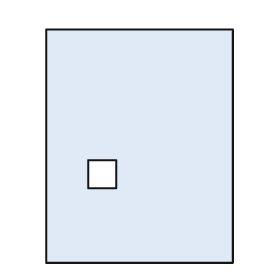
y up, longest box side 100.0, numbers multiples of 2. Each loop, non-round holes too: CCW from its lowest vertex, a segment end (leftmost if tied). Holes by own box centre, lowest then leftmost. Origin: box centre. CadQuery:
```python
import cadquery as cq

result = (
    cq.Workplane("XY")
    .moveTo(-40.0, -50.0)
    .lineTo(40.0, -50.0)
    .lineTo(40.0, 50.0)
    .lineTo(-40.0, 50.0)
    .close()
    .moveTo(-22.0, -18.0)
    .lineTo(-10.0, -18.0)
    .lineTo(-10.0, -6.0)
    .lineTo(-22.0, -6.0)
    .close()
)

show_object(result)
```